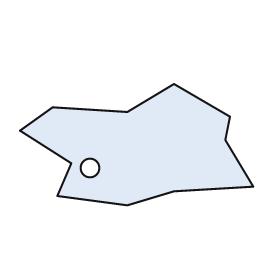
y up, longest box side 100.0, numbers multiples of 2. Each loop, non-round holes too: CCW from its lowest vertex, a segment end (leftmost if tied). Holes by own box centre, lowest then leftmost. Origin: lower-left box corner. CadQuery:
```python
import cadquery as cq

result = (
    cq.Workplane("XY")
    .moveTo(46.0, 0.0)
    .lineTo(66.0, 6.0)
    .lineTo(100.0, 8.0)
    .lineTo(88.0, 28.0)
    .lineTo(90.0, 38.0)
    .lineTo(66.0, 52.0)
    .lineTo(46.0, 40.0)
    .lineTo(14.0, 42.0)
    .lineTo(0.0, 32.0)
    .lineTo(22.0, 18.0)
    .lineTo(16.0, 4.0)
    .close()
    .moveTo(30.0, 16.0)
    .circle(4.0)
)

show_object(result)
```